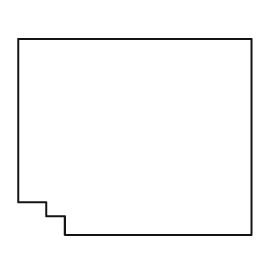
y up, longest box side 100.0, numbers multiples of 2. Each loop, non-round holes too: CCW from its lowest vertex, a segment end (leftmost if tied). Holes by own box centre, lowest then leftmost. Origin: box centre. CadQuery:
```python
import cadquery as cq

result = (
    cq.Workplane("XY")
    .moveTo(-30.0, -42.0)
    .lineTo(50.0, -42.0)
    .lineTo(50.0, 42.0)
    .lineTo(-50.0, 42.0)
    .lineTo(-50.0, -28.0)
    .lineTo(-38.0, -28.0)
    .lineTo(-38.0, -34.0)
    .lineTo(-30.0, -34.0)
    .close()
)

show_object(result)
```